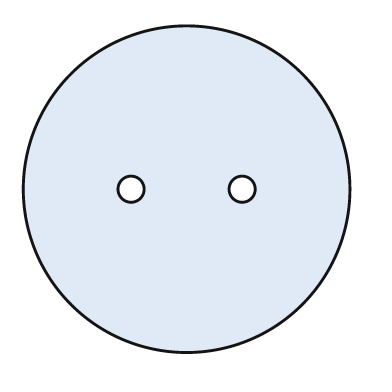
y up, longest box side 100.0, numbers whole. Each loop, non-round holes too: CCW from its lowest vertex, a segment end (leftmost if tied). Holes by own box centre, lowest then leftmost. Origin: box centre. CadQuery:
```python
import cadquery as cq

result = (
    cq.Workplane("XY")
    .moveTo(0.0, 0.0)
    .circle(50.0)
    .moveTo(-17.0, 0.0)
    .circle(4.0)
    .moveTo(17.0, 0.0)
    .circle(4.0)
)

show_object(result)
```